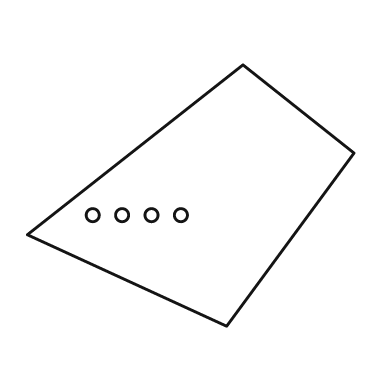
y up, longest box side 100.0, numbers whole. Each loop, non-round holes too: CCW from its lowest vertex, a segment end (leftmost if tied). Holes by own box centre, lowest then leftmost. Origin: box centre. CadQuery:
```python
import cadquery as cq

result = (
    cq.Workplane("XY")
    .moveTo(11.0, -40.0)
    .lineTo(50.0, 13.0)
    .lineTo(16.0, 40.0)
    .lineTo(-50.0, -12.0)
    .close()
    .moveTo(-30.0, -6.0)
    .circle(2.0)
    .moveTo(-21.0, -6.0)
    .circle(2.0)
    .moveTo(-12.0, -6.0)
    .circle(2.0)
    .moveTo(-3.0, -6.0)
    .circle(2.0)
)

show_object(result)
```